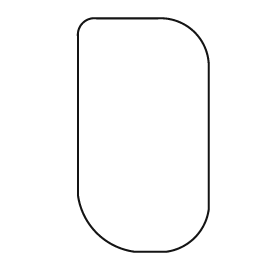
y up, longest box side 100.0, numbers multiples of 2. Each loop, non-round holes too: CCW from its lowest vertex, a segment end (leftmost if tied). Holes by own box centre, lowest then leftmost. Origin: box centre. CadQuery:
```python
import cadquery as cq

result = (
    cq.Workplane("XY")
    .moveTo(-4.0, -50.0)
    .lineTo(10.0, -50.0)
    .threePointArc((22.0, -44.0), (28.0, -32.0))
    .lineTo(28.0, 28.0)
    .threePointArc((22.0, 44.0), (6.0, 50.0))
    .lineTo(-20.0, 50.0)
    .threePointArc((-26.0, 48.0), (-28.0, 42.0))
    .lineTo(-28.0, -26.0)
    .threePointArc((-20.0, -42.0), (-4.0, -50.0))
    .close()
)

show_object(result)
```